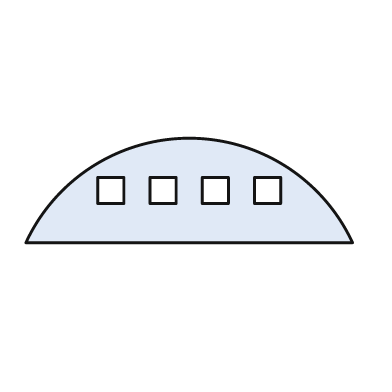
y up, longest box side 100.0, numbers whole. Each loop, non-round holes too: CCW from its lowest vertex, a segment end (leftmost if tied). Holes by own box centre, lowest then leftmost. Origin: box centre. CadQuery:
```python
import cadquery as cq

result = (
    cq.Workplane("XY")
    .moveTo(-50.0, -16.0)
    .lineTo(50.0, -16.0)
    .threePointArc((0.0, 16.0), (-50.0, -16.0))
    .close()
    .moveTo(-28.0, -4.0)
    .lineTo(-20.0, -4.0)
    .lineTo(-20.0, 4.0)
    .lineTo(-28.0, 4.0)
    .close()
    .moveTo(-12.0, -4.0)
    .lineTo(-4.0, -4.0)
    .lineTo(-4.0, 4.0)
    .lineTo(-12.0, 4.0)
    .close()
    .moveTo(4.0, -4.0)
    .lineTo(12.0, -4.0)
    .lineTo(12.0, 4.0)
    .lineTo(4.0, 4.0)
    .close()
    .moveTo(20.0, -4.0)
    .lineTo(28.0, -4.0)
    .lineTo(28.0, 4.0)
    .lineTo(20.0, 4.0)
    .close()
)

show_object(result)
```